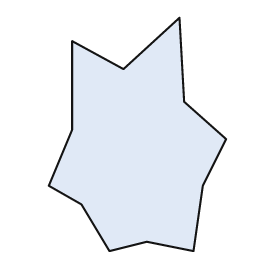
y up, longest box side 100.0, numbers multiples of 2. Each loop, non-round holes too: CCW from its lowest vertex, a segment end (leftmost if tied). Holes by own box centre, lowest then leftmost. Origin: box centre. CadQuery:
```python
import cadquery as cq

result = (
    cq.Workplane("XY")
    .moveTo(-12.0, -50.0)
    .lineTo(4.0, -46.0)
    .lineTo(24.0, -50.0)
    .lineTo(28.0, -22.0)
    .lineTo(38.0, -2.0)
    .lineTo(20.0, 14.0)
    .lineTo(18.0, 50.0)
    .lineTo(-6.0, 28.0)
    .lineTo(-28.0, 40.0)
    .lineTo(-28.0, 2.0)
    .lineTo(-38.0, -22.0)
    .lineTo(-24.0, -30.0)
    .close()
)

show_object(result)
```